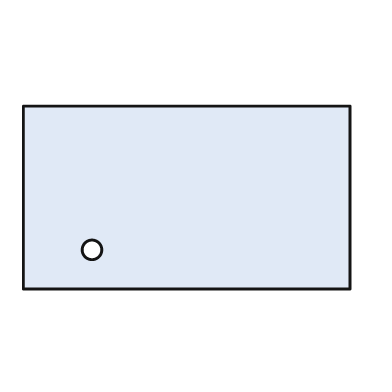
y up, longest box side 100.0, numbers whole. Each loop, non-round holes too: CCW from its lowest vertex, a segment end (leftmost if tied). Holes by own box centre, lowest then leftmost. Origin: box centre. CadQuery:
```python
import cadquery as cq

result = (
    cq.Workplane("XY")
    .moveTo(-50.0, -28.0)
    .lineTo(50.0, -28.0)
    .lineTo(50.0, 28.0)
    .lineTo(-50.0, 28.0)
    .close()
    .moveTo(-29.0, -16.0)
    .circle(3.0)
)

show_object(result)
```